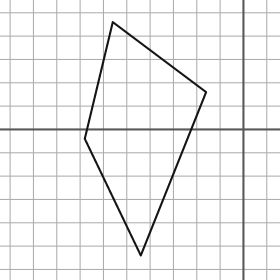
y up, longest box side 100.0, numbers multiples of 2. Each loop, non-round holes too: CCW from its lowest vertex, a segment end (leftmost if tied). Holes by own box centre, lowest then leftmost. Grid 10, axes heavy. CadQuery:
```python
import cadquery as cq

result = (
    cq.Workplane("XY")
    .moveTo(-44.0, -54.0)
    .lineTo(-16.0, 16.0)
    .lineTo(-56.0, 46.0)
    .lineTo(-68.0, -4.0)
    .close()
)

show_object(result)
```